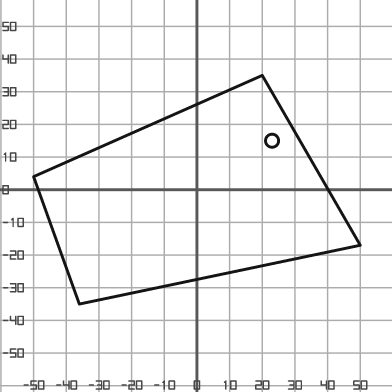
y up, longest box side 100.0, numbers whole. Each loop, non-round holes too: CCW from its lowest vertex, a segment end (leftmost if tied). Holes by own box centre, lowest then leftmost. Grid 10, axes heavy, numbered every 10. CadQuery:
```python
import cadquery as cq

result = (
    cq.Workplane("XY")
    .moveTo(-36.0, -35.0)
    .lineTo(50.0, -17.0)
    .lineTo(20.0, 35.0)
    .lineTo(-50.0, 4.0)
    .close()
    .moveTo(23.0, 15.0)
    .circle(2.0)
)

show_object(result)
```